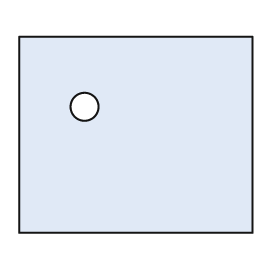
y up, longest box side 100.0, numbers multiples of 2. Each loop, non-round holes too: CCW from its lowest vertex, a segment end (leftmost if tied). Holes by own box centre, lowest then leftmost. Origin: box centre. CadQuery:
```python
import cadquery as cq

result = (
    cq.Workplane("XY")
    .moveTo(-50.0, -42.0)
    .lineTo(50.0, -42.0)
    .lineTo(50.0, 42.0)
    .lineTo(-50.0, 42.0)
    .close()
    .moveTo(-22.0, 12.0)
    .circle(6.0)
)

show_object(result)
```